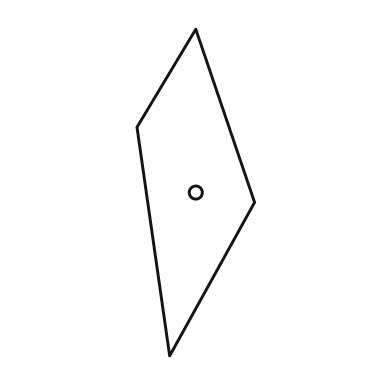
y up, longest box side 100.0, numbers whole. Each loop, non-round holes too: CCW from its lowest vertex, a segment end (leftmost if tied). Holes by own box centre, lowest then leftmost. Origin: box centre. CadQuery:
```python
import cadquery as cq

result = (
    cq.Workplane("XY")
    .moveTo(-8.0, -50.0)
    .lineTo(18.0, -3.0)
    .lineTo(0.0, 50.0)
    .lineTo(-18.0, 20.0)
    .close()
    .moveTo(0.0, 0.0)
    .circle(2.0)
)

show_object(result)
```